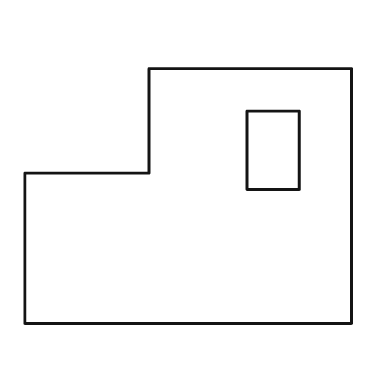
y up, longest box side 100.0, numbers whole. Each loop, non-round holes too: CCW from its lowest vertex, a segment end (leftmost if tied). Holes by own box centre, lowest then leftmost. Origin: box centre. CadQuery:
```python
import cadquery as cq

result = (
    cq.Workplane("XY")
    .moveTo(-50.0, -39.0)
    .lineTo(50.0, -39.0)
    .lineTo(50.0, 39.0)
    .lineTo(-12.0, 39.0)
    .lineTo(-12.0, 7.0)
    .lineTo(-50.0, 7.0)
    .close()
    .moveTo(18.0, 2.0)
    .lineTo(34.0, 2.0)
    .lineTo(34.0, 26.0)
    .lineTo(18.0, 26.0)
    .close()
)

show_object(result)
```